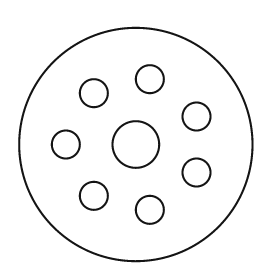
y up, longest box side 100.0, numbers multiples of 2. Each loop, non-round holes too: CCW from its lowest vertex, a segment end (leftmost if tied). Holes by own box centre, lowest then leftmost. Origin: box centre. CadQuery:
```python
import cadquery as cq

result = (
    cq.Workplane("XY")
    .moveTo(0.0, 0.0)
    .circle(50.0)
    .moveTo(6.0, -28.0)
    .circle(6.0)
    .moveTo(-18.0, -22.0)
    .circle(6.0)
    .moveTo(26.0, -12.0)
    .circle(6.0)
    .moveTo(-30.0, 0.0)
    .circle(6.0)
    .moveTo(0.0, 0.0)
    .circle(10.0)
    .moveTo(26.0, 12.0)
    .circle(6.0)
    .moveTo(-18.0, 22.0)
    .circle(6.0)
    .moveTo(6.0, 28.0)
    .circle(6.0)
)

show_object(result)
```